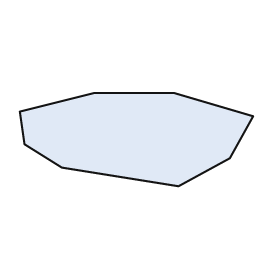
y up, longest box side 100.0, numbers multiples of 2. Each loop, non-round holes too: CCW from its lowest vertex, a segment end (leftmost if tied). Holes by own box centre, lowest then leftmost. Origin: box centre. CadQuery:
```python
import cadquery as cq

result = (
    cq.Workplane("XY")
    .moveTo(18.0, -20.0)
    .lineTo(40.0, -8.0)
    .lineTo(50.0, 10.0)
    .lineTo(16.0, 20.0)
    .lineTo(-18.0, 20.0)
    .lineTo(-50.0, 12.0)
    .lineTo(-48.0, -2.0)
    .lineTo(-32.0, -12.0)
    .close()
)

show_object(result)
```